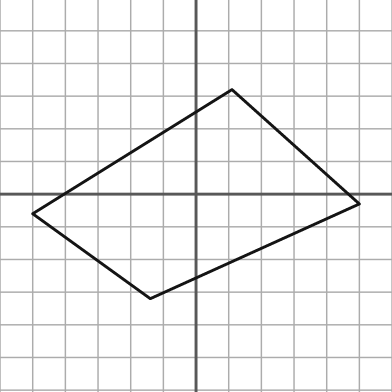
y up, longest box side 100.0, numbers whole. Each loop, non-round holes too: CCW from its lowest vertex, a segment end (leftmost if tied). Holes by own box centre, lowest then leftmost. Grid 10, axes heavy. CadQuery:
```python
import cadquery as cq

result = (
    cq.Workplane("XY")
    .moveTo(-14.0, -32.0)
    .lineTo(50.0, -3.0)
    .lineTo(11.0, 32.0)
    .lineTo(-50.0, -6.0)
    .close()
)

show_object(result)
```